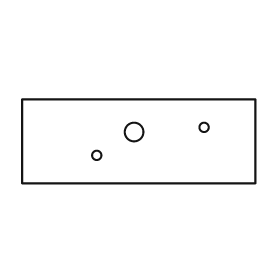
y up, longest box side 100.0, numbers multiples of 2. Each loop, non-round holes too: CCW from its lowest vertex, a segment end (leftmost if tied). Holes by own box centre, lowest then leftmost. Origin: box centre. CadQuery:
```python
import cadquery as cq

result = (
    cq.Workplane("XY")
    .moveTo(-50.0, -18.0)
    .lineTo(50.0, -18.0)
    .lineTo(50.0, 18.0)
    .lineTo(-50.0, 18.0)
    .close()
    .moveTo(-18.0, -6.0)
    .circle(2.0)
    .moveTo(-2.0, 4.0)
    .circle(4.0)
    .moveTo(28.0, 6.0)
    .circle(2.0)
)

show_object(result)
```